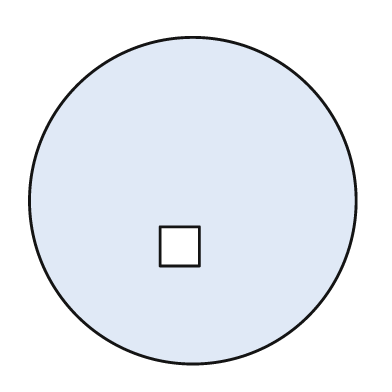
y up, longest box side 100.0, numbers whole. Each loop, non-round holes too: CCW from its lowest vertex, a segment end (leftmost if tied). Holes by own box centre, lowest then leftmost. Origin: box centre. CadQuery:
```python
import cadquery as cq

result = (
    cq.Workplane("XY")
    .moveTo(0.0, 0.0)
    .circle(50.0)
    .moveTo(-10.0, -20.0)
    .lineTo(2.0, -20.0)
    .lineTo(2.0, -8.0)
    .lineTo(-10.0, -8.0)
    .close()
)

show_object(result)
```